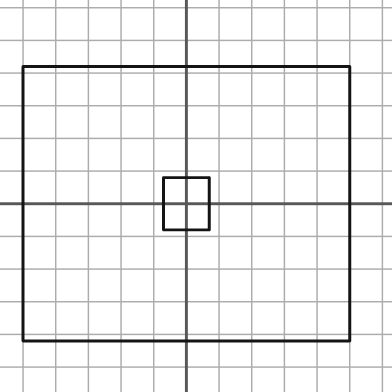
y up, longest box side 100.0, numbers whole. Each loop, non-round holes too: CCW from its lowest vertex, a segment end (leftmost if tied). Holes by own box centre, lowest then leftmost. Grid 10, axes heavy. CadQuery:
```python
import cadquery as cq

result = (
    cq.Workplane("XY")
    .moveTo(-50.0, -42.0)
    .lineTo(50.0, -42.0)
    .lineTo(50.0, 42.0)
    .lineTo(-50.0, 42.0)
    .close()
    .moveTo(-7.0, -8.0)
    .lineTo(7.0, -8.0)
    .lineTo(7.0, 8.0)
    .lineTo(-7.0, 8.0)
    .close()
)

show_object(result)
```